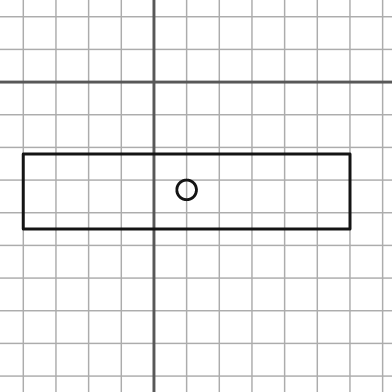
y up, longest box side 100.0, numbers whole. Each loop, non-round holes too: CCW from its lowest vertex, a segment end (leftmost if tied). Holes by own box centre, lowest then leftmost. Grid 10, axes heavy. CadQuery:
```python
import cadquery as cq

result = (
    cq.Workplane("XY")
    .moveTo(-40.0, -45.0)
    .lineTo(60.0, -45.0)
    .lineTo(60.0, -22.0)
    .lineTo(-40.0, -22.0)
    .close()
    .moveTo(10.0, -33.0)
    .circle(3.0)
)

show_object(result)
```